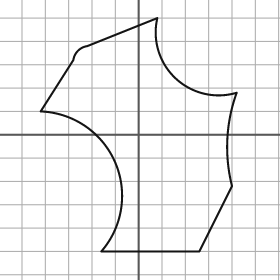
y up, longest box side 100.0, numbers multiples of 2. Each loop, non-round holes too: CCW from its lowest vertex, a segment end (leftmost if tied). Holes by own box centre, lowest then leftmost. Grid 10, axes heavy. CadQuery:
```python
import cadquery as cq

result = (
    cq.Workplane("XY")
    .moveTo(-16.0, -50.0)
    .lineTo(26.0, -50.0)
    .lineTo(40.0, -22.0)
    .threePointArc((38.0, -2.0), (42.0, 18.0))
    .threePointArc((16.0, 24.0), (8.0, 50.0))
    .lineTo(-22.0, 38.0)
    .threePointArc((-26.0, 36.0), (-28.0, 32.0))
    .lineTo(-42.0, 10.0)
    .threePointArc((-10.0, -12.0), (-16.0, -50.0))
    .close()
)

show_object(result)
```